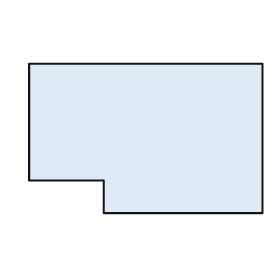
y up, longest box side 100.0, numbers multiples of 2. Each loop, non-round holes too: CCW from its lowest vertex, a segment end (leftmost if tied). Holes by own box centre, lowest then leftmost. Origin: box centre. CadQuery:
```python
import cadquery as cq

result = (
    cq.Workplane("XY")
    .moveTo(-18.0, -32.0)
    .lineTo(50.0, -32.0)
    .lineTo(50.0, 32.0)
    .lineTo(-50.0, 32.0)
    .lineTo(-50.0, -18.0)
    .lineTo(-18.0, -18.0)
    .close()
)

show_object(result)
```